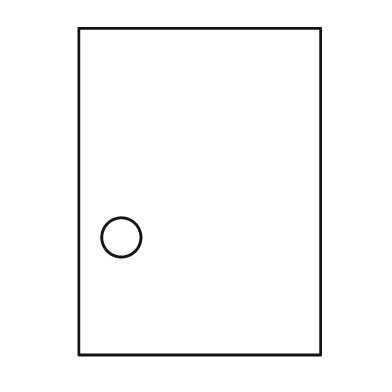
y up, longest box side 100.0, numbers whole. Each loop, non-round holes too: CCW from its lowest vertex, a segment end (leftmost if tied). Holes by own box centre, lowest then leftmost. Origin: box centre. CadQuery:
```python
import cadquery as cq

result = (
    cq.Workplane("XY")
    .moveTo(-37.0, -50.0)
    .lineTo(37.0, -50.0)
    .lineTo(37.0, 50.0)
    .lineTo(-37.0, 50.0)
    .close()
    .moveTo(-24.0, -14.0)
    .circle(6.0)
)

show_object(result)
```